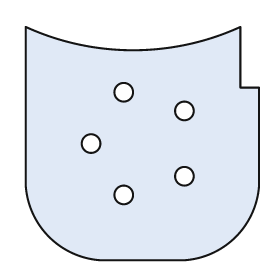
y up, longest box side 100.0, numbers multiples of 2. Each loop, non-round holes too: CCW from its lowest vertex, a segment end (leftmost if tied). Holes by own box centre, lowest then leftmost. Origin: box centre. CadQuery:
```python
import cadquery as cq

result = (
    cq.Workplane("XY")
    .moveTo(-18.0, -50.0)
    .lineTo(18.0, -50.0)
    .threePointArc((40.0, -40.0), (50.0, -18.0))
    .lineTo(50.0, 24.0)
    .lineTo(42.0, 24.0)
    .lineTo(42.0, 50.0)
    .threePointArc((-4.0, 40.0), (-50.0, 50.0))
    .lineTo(-50.0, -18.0)
    .threePointArc((-40.0, -40.0), (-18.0, -50.0))
    .close()
    .moveTo(-8.0, -22.0)
    .circle(4.0)
    .moveTo(18.0, -14.0)
    .circle(4.0)
    .moveTo(-22.0, 0.0)
    .circle(4.0)
    .moveTo(18.0, 14.0)
    .circle(4.0)
    .moveTo(-8.0, 22.0)
    .circle(4.0)
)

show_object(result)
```